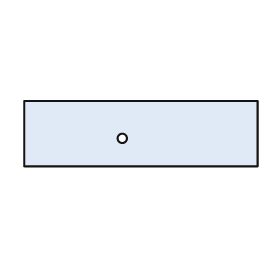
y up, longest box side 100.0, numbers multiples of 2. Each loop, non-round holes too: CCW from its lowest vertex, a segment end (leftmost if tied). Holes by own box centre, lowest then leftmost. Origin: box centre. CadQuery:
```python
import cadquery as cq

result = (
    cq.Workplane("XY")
    .moveTo(-50.0, -14.0)
    .lineTo(50.0, -14.0)
    .lineTo(50.0, 14.0)
    .lineTo(-50.0, 14.0)
    .close()
    .moveTo(-8.0, -2.0)
    .circle(2.0)
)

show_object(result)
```